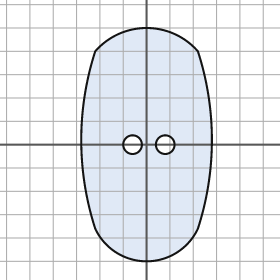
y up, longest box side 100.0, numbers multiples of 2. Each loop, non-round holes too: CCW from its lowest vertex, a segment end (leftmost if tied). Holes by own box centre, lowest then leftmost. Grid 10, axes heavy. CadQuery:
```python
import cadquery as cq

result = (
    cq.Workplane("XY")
    .moveTo(-22.0, -36.0)
    .threePointArc((0.0, -50.0), (22.0, -36.0))
    .threePointArc((28.0, 2.0), (22.0, 40.0))
    .threePointArc((0.0, 50.0), (-22.0, 40.0))
    .threePointArc((-28.0, 2.0), (-22.0, -36.0))
    .close()
    .moveTo(-6.0, 0.0)
    .circle(4.0)
    .moveTo(8.0, 0.0)
    .circle(4.0)
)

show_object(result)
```